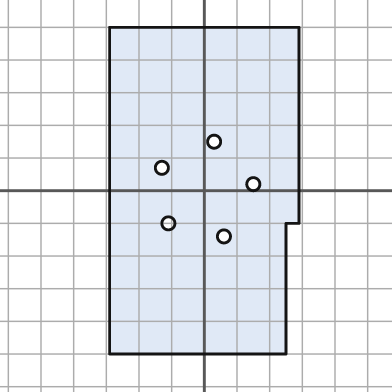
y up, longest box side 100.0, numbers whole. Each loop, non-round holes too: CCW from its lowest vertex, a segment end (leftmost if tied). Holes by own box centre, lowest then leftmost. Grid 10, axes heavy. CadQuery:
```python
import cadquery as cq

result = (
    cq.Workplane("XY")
    .moveTo(-29.0, -50.0)
    .lineTo(25.0, -50.0)
    .lineTo(25.0, -10.0)
    .lineTo(29.0, -10.0)
    .lineTo(29.0, 50.0)
    .lineTo(-29.0, 50.0)
    .close()
    .moveTo(6.0, -14.0)
    .circle(2.0)
    .moveTo(-11.0, -10.0)
    .circle(2.0)
    .moveTo(15.0, 2.0)
    .circle(2.0)
    .moveTo(-13.0, 7.0)
    .circle(2.0)
    .moveTo(3.0, 15.0)
    .circle(2.0)
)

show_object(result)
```